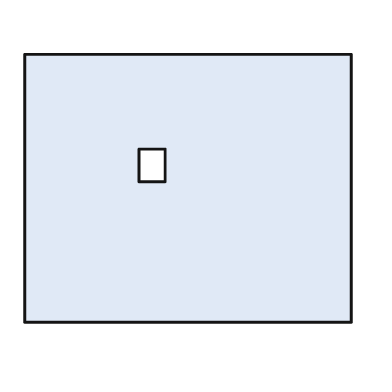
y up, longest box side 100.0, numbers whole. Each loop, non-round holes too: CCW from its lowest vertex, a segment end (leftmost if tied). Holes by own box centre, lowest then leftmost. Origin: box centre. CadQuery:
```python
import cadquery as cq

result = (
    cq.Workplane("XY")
    .moveTo(-50.0, -41.0)
    .lineTo(50.0, -41.0)
    .lineTo(50.0, 41.0)
    .lineTo(-50.0, 41.0)
    .close()
    .moveTo(-15.0, 2.0)
    .lineTo(-7.0, 2.0)
    .lineTo(-7.0, 12.0)
    .lineTo(-15.0, 12.0)
    .close()
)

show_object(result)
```